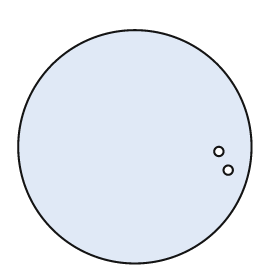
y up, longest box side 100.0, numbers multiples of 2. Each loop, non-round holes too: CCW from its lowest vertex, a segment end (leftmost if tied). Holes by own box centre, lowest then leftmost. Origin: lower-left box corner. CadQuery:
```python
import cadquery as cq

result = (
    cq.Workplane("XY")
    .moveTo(50.0, 50.0)
    .circle(50.0)
    .moveTo(90.0, 40.0)
    .circle(2.0)
    .moveTo(86.0, 48.0)
    .circle(2.0)
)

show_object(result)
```